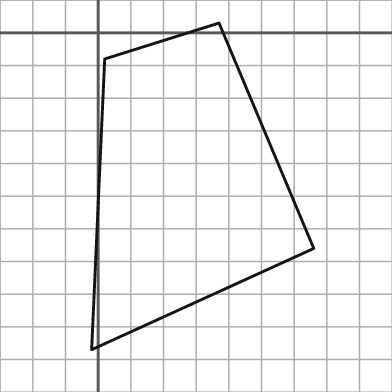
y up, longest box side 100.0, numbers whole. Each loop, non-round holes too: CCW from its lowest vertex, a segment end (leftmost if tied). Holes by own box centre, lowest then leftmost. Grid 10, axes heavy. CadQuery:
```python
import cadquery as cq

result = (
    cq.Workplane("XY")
    .moveTo(-2.0, -97.0)
    .lineTo(66.0, -66.0)
    .lineTo(37.0, 3.0)
    .lineTo(2.0, -8.0)
    .close()
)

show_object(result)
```